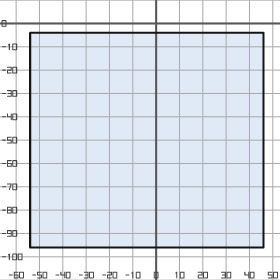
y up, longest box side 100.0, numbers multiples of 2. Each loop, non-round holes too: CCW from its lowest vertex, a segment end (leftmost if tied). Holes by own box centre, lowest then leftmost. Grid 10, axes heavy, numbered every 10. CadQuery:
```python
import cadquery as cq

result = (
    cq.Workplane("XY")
    .moveTo(-54.0, -96.0)
    .lineTo(46.0, -96.0)
    .lineTo(46.0, -4.0)
    .lineTo(-54.0, -4.0)
    .close()
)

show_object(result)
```